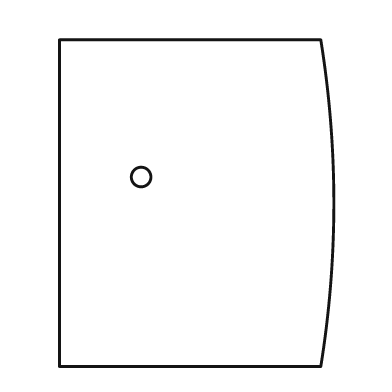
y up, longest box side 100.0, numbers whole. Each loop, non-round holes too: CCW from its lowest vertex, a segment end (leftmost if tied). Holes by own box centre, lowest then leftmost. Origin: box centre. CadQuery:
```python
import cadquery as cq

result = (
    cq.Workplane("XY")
    .moveTo(-42.0, -50.0)
    .lineTo(38.0, -50.0)
    .threePointArc((42.0, 0.0), (38.0, 50.0))
    .lineTo(-42.0, 50.0)
    .close()
    .moveTo(-17.0, 8.0)
    .circle(3.0)
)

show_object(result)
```